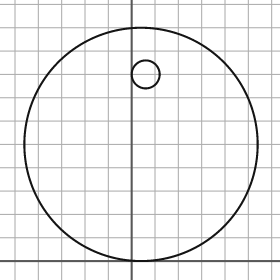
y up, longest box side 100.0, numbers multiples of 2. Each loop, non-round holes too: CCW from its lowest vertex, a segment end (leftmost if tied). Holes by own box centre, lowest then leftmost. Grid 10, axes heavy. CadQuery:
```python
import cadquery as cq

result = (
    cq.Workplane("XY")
    .moveTo(4.0, 50.0)
    .circle(50.0)
    .moveTo(6.0, 80.0)
    .circle(6.0)
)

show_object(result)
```